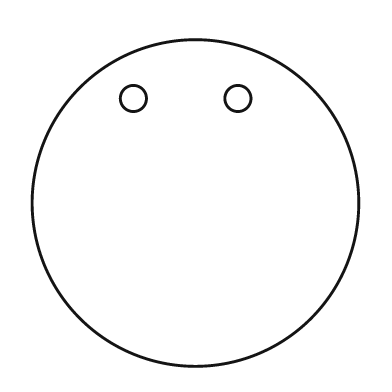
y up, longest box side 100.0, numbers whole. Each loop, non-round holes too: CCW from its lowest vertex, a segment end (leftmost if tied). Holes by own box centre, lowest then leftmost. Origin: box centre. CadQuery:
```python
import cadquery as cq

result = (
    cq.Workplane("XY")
    .moveTo(0.0, 0.0)
    .circle(50.0)
    .moveTo(-19.0, 32.0)
    .circle(4.0)
    .moveTo(13.0, 32.0)
    .circle(4.0)
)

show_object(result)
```